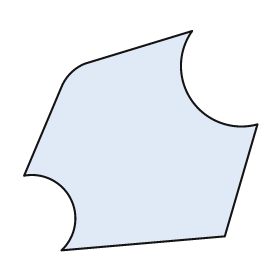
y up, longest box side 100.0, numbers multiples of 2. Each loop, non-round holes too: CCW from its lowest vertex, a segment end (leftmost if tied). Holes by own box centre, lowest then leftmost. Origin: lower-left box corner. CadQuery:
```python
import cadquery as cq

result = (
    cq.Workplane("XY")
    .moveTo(16.0, 0.0)
    .lineTo(86.0, 6.0)
    .lineTo(100.0, 54.0)
    .threePointArc((72.0, 64.0), (72.0, 94.0))
    .lineTo(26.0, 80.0)
    .threePointArc((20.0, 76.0), (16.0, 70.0))
    .lineTo(0.0, 32.0)
    .threePointArc((20.0, 22.0), (16.0, 0.0))
    .close()
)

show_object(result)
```